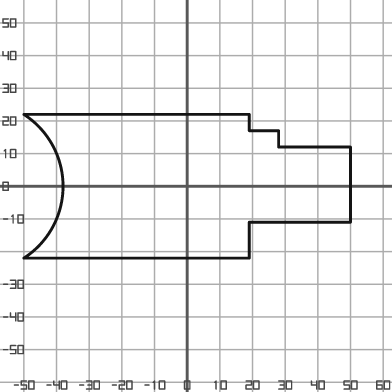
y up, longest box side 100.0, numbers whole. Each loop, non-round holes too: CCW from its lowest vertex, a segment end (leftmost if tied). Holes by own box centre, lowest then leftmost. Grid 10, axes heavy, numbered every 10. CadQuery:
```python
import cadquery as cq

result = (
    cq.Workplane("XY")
    .moveTo(-50.0, -22.0)
    .lineTo(19.0, -22.0)
    .lineTo(19.0, -11.0)
    .lineTo(50.0, -11.0)
    .lineTo(50.0, 12.0)
    .lineTo(28.0, 12.0)
    .lineTo(28.0, 17.0)
    .lineTo(19.0, 17.0)
    .lineTo(19.0, 22.0)
    .lineTo(-50.0, 22.0)
    .threePointArc((-38.0, 0.0), (-50.0, -22.0))
    .close()
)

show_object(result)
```